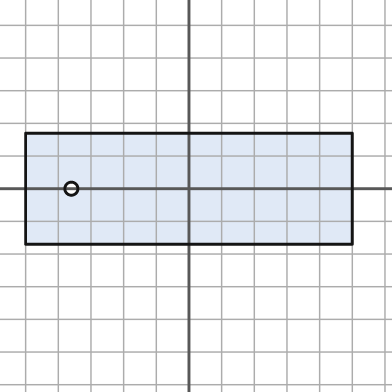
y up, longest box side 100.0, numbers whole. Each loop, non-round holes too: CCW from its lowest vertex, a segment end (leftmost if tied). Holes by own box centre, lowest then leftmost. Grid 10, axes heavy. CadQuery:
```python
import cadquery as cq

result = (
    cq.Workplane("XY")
    .moveTo(-50.0, -17.0)
    .lineTo(50.0, -17.0)
    .lineTo(50.0, 17.0)
    .lineTo(-50.0, 17.0)
    .close()
    .moveTo(-36.0, 0.0)
    .circle(2.0)
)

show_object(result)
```